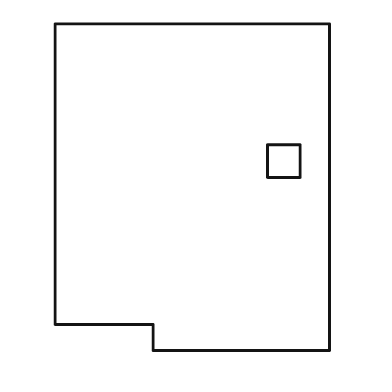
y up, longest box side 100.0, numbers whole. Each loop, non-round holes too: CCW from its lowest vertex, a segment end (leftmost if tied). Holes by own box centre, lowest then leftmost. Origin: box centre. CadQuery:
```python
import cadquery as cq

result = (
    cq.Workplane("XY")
    .moveTo(-12.0, -50.0)
    .lineTo(42.0, -50.0)
    .lineTo(42.0, 50.0)
    .lineTo(-42.0, 50.0)
    .lineTo(-42.0, -42.0)
    .lineTo(-12.0, -42.0)
    .close()
    .moveTo(23.0, 3.0)
    .lineTo(33.0, 3.0)
    .lineTo(33.0, 13.0)
    .lineTo(23.0, 13.0)
    .close()
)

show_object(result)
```